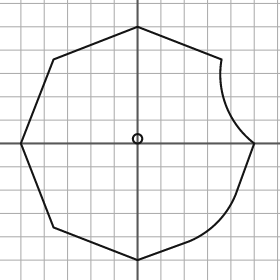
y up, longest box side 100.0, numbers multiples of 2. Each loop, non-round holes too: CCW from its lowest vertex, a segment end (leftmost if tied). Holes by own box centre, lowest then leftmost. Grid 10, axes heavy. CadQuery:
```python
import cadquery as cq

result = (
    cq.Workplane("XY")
    .moveTo(0.0, -50.0)
    .lineTo(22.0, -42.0)
    .threePointArc((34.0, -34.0), (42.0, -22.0))
    .lineTo(50.0, 0.0)
    .threePointArc((38.0, 16.0), (36.0, 36.0))
    .lineTo(0.0, 50.0)
    .lineTo(-36.0, 36.0)
    .lineTo(-50.0, 0.0)
    .lineTo(-36.0, -36.0)
    .close()
    .moveTo(0.0, 2.0)
    .circle(2.0)
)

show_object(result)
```